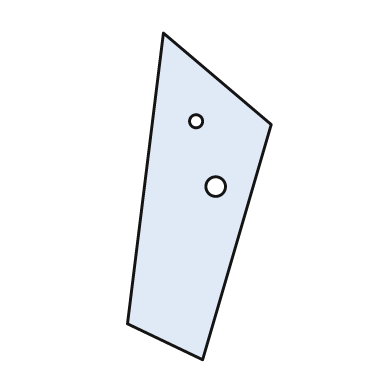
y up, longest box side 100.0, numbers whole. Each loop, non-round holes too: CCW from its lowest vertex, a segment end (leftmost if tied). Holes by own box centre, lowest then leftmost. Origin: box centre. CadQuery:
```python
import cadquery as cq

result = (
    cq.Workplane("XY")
    .moveTo(1.0, -50.0)
    .lineTo(22.0, 22.0)
    .lineTo(-11.0, 50.0)
    .lineTo(-22.0, -39.0)
    .close()
    .moveTo(5.0, 3.0)
    .circle(3.0)
    .moveTo(-1.0, 23.0)
    .circle(2.0)
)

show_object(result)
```